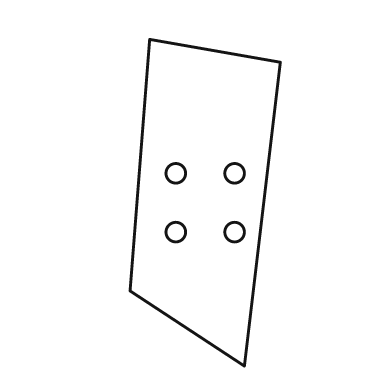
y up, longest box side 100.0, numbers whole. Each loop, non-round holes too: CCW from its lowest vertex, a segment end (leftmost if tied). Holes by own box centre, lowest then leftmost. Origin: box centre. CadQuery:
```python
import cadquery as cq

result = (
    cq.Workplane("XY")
    .moveTo(12.0, -50.0)
    .lineTo(23.0, 43.0)
    .lineTo(-17.0, 50.0)
    .lineTo(-23.0, -27.0)
    .close()
    .moveTo(-9.0, -9.0)
    .circle(3.0)
    .moveTo(9.0, -9.0)
    .circle(3.0)
    .moveTo(-9.0, 9.0)
    .circle(3.0)
    .moveTo(9.0, 9.0)
    .circle(3.0)
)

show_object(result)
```